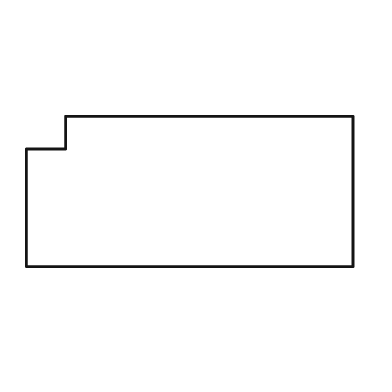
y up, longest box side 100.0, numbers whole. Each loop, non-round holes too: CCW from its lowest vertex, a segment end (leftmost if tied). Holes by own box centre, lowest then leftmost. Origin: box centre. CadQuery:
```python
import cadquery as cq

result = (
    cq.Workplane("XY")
    .moveTo(-50.0, -23.0)
    .lineTo(50.0, -23.0)
    .lineTo(50.0, 23.0)
    .lineTo(-38.0, 23.0)
    .lineTo(-38.0, 13.0)
    .lineTo(-50.0, 13.0)
    .close()
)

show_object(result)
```